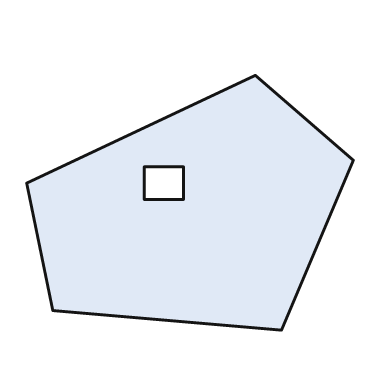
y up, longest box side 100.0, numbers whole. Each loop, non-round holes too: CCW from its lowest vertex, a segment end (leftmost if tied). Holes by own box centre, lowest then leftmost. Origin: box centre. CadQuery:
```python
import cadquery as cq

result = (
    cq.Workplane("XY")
    .moveTo(28.0, -39.0)
    .lineTo(50.0, 13.0)
    .lineTo(20.0, 39.0)
    .lineTo(-50.0, 6.0)
    .lineTo(-42.0, -33.0)
    .close()
    .moveTo(-14.0, 1.0)
    .lineTo(-2.0, 1.0)
    .lineTo(-2.0, 11.0)
    .lineTo(-14.0, 11.0)
    .close()
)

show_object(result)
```